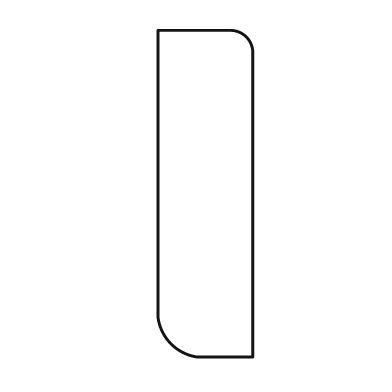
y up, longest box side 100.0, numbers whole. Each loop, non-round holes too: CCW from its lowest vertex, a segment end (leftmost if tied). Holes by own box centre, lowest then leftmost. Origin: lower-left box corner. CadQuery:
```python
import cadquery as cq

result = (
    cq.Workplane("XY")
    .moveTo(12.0, 0.0)
    .lineTo(29.0, 0.0)
    .lineTo(29.0, 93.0)
    .threePointArc((27.0, 98.0), (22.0, 100.0))
    .lineTo(0.0, 100.0)
    .lineTo(0.0, 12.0)
    .threePointArc((4.0, 4.0), (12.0, 0.0))
    .close()
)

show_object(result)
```